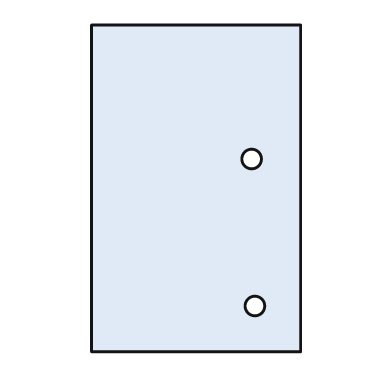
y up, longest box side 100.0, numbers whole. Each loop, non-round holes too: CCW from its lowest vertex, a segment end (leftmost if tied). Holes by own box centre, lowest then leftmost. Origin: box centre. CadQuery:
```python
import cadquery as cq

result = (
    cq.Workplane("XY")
    .moveTo(-32.0, -50.0)
    .lineTo(32.0, -50.0)
    .lineTo(32.0, 50.0)
    .lineTo(-32.0, 50.0)
    .close()
    .moveTo(18.0, -36.0)
    .circle(3.0)
    .moveTo(17.0, 9.0)
    .circle(3.0)
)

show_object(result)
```